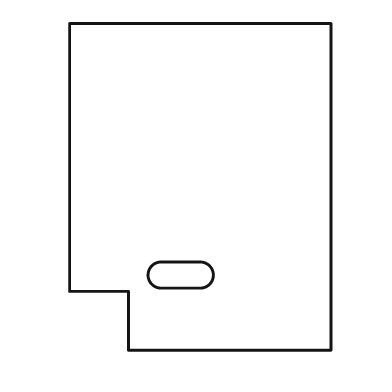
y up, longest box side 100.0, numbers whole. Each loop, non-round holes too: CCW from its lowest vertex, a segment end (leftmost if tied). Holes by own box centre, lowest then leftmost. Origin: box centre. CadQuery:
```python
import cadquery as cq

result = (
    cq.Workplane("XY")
    .moveTo(-22.0, -50.0)
    .lineTo(40.0, -50.0)
    .lineTo(40.0, 50.0)
    .lineTo(-40.0, 50.0)
    .lineTo(-40.0, -32.0)
    .lineTo(-22.0, -32.0)
    .close()
    .moveTo(-12.0, -31.0)
    .lineTo(0.0, -31.0)
    .threePointArc((4.0, -27.0), (0.0, -23.0))
    .lineTo(-12.0, -23.0)
    .threePointArc((-16.0, -27.0), (-12.0, -31.0))
    .close()
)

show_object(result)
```